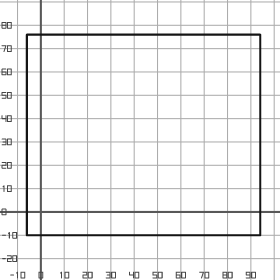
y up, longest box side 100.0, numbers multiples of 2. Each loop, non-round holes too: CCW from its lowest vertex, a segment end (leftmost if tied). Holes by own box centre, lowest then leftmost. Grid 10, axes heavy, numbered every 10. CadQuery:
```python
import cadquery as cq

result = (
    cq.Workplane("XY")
    .moveTo(-6.0, -10.0)
    .lineTo(94.0, -10.0)
    .lineTo(94.0, 76.0)
    .lineTo(-6.0, 76.0)
    .close()
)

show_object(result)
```